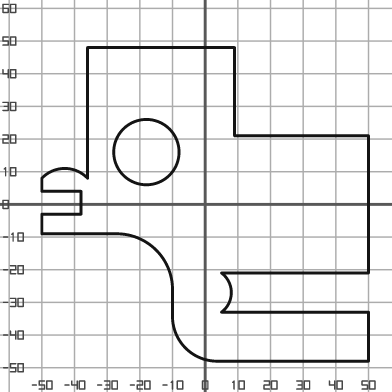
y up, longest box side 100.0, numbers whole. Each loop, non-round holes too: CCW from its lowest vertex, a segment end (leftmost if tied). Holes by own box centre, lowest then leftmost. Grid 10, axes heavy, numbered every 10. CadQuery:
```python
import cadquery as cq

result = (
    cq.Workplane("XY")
    .moveTo(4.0, -48.0)
    .lineTo(50.0, -48.0)
    .lineTo(50.0, -33.0)
    .lineTo(5.0, -33.0)
    .threePointArc((8.0, -27.0), (5.0, -21.0))
    .lineTo(50.0, -21.0)
    .lineTo(50.0, 21.0)
    .lineTo(9.0, 21.0)
    .lineTo(9.0, 48.0)
    .lineTo(-36.0, 48.0)
    .lineTo(-36.0, 8.0)
    .threePointArc((-43.0, 11.0), (-50.0, 8.0))
    .lineTo(-50.0, 4.0)
    .lineTo(-38.0, 4.0)
    .lineTo(-38.0, -3.0)
    .lineTo(-50.0, -3.0)
    .lineTo(-50.0, -9.0)
    .lineTo(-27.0, -9.0)
    .threePointArc((-15.0, -14.0), (-10.0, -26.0))
    .lineTo(-10.0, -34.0)
    .threePointArc((-6.0, -44.0), (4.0, -48.0))
    .close()
    .moveTo(-18.0, 16.0)
    .circle(10.0)
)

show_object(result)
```